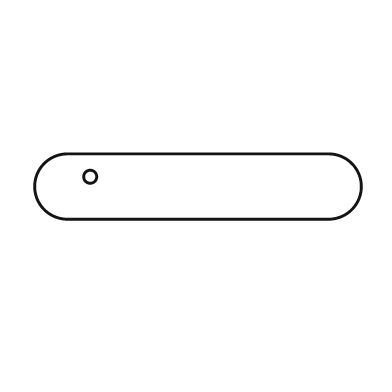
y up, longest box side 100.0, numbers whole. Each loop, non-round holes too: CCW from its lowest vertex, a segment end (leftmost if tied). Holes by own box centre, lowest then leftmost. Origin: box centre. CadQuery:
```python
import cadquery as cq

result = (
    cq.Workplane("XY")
    .moveTo(-40.0, -10.0)
    .lineTo(40.0, -10.0)
    .threePointArc((50.0, 0.0), (40.0, 10.0))
    .lineTo(-40.0, 10.0)
    .threePointArc((-50.0, 0.0), (-40.0, -10.0))
    .close()
    .moveTo(-33.0, 3.0)
    .circle(2.0)
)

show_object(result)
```